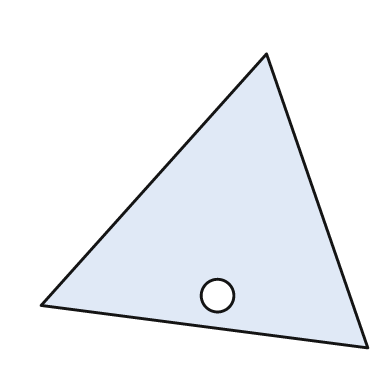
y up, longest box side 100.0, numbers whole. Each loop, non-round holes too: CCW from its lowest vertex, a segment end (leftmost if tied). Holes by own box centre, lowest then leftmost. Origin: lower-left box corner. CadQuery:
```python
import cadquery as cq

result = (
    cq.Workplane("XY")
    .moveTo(100.0, 0.0)
    .lineTo(69.0, 90.0)
    .lineTo(0.0, 13.0)
    .close()
    .moveTo(54.0, 16.0)
    .circle(5.0)
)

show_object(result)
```